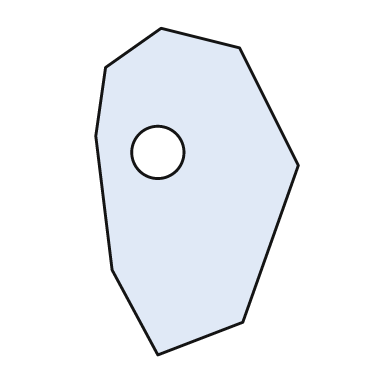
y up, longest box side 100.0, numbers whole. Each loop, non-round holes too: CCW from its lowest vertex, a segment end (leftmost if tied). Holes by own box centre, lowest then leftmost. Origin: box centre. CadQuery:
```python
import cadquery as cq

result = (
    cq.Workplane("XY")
    .moveTo(-12.0, -50.0)
    .lineTo(14.0, -40.0)
    .lineTo(31.0, 8.0)
    .lineTo(13.0, 44.0)
    .lineTo(-11.0, 50.0)
    .lineTo(-28.0, 38.0)
    .lineTo(-31.0, 17.0)
    .lineTo(-26.0, -24.0)
    .close()
    .moveTo(-12.0, 12.0)
    .circle(8.0)
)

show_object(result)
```